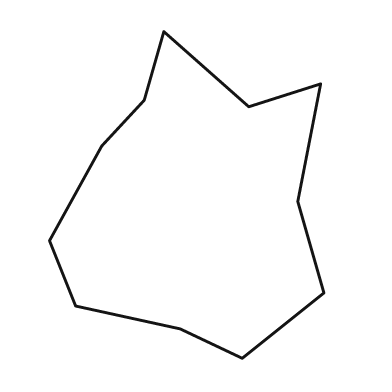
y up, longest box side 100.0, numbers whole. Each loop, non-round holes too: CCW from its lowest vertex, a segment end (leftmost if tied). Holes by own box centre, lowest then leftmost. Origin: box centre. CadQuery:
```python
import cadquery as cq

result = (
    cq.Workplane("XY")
    .moveTo(17.0, -50.0)
    .lineTo(42.0, -30.0)
    .lineTo(34.0, -2.0)
    .lineTo(41.0, 34.0)
    .lineTo(19.0, 27.0)
    .lineTo(-7.0, 50.0)
    .lineTo(-13.0, 29.0)
    .lineTo(-26.0, 15.0)
    .lineTo(-42.0, -14.0)
    .lineTo(-34.0, -34.0)
    .lineTo(-2.0, -41.0)
    .close()
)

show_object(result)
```